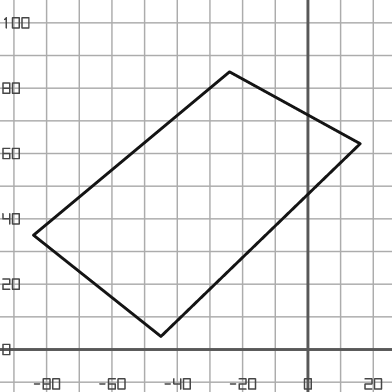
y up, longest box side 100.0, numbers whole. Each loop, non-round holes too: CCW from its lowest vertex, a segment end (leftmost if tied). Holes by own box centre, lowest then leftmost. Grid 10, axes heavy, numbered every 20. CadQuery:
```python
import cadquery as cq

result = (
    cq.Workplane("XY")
    .moveTo(-45.0, 4.0)
    .lineTo(16.0, 63.0)
    .lineTo(-24.0, 85.0)
    .lineTo(-84.0, 35.0)
    .close()
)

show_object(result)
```